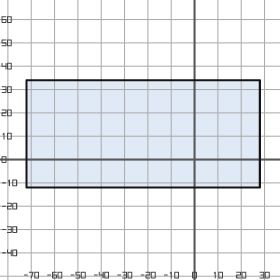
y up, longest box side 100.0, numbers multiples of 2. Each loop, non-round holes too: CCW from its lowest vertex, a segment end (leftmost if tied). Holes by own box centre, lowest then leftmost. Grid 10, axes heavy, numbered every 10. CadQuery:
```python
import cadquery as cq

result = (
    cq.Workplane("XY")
    .moveTo(-72.0, -12.0)
    .lineTo(28.0, -12.0)
    .lineTo(28.0, 34.0)
    .lineTo(-72.0, 34.0)
    .close()
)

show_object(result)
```